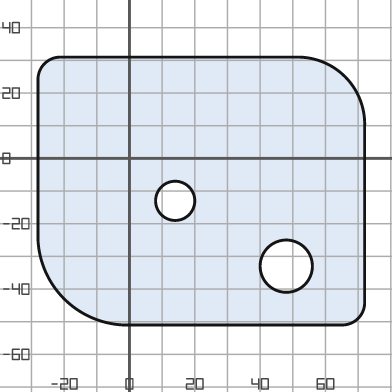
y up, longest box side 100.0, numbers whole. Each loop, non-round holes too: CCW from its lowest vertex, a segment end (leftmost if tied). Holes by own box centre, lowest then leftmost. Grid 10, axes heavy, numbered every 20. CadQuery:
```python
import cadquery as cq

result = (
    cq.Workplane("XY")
    .moveTo(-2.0, -51.0)
    .lineTo(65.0, -51.0)
    .threePointArc((70.0, -49.0), (72.0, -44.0))
    .lineTo(72.0, 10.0)
    .threePointArc((66.0, 25.0), (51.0, 31.0))
    .lineTo(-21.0, 31.0)
    .threePointArc((-26.0, 29.0), (-28.0, 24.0))
    .lineTo(-28.0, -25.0)
    .threePointArc((-20.0, -43.0), (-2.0, -51.0))
    .close()
    .moveTo(48.0, -33.0)
    .circle(8.0)
    .moveTo(14.0, -13.0)
    .circle(6.0)
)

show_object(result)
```